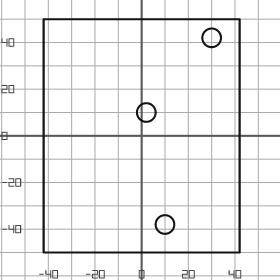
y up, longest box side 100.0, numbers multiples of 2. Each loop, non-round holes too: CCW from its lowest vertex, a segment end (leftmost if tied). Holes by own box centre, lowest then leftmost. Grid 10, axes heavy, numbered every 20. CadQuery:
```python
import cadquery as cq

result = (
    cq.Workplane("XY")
    .moveTo(-42.0, -50.0)
    .lineTo(42.0, -50.0)
    .lineTo(42.0, 50.0)
    .lineTo(-42.0, 50.0)
    .close()
    .moveTo(10.0, -38.0)
    .circle(4.0)
    .moveTo(2.0, 10.0)
    .circle(4.0)
    .moveTo(30.0, 42.0)
    .circle(4.0)
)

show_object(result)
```